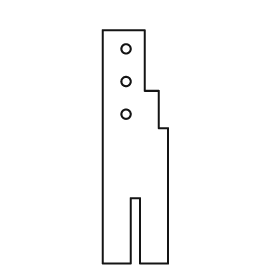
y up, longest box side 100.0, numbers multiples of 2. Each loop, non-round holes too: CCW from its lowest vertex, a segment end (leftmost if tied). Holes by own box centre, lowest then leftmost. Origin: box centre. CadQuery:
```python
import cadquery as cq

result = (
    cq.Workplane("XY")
    .moveTo(-14.0, -50.0)
    .lineTo(-2.0, -50.0)
    .lineTo(-2.0, -22.0)
    .lineTo(2.0, -22.0)
    .lineTo(2.0, -50.0)
    .lineTo(14.0, -50.0)
    .lineTo(14.0, 8.0)
    .lineTo(10.0, 8.0)
    .lineTo(10.0, 24.0)
    .lineTo(4.0, 24.0)
    .lineTo(4.0, 50.0)
    .lineTo(-14.0, 50.0)
    .close()
    .moveTo(-4.0, 14.0)
    .circle(2.0)
    .moveTo(-4.0, 28.0)
    .circle(2.0)
    .moveTo(-4.0, 42.0)
    .circle(2.0)
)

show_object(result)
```